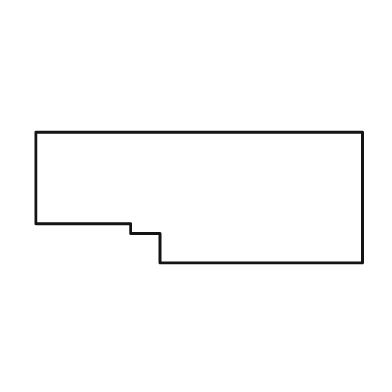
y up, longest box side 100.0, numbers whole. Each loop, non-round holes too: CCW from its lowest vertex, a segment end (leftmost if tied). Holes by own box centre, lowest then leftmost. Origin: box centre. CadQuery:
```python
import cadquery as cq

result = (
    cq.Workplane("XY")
    .moveTo(-12.0, -20.0)
    .lineTo(50.0, -20.0)
    .lineTo(50.0, 20.0)
    .lineTo(-50.0, 20.0)
    .lineTo(-50.0, -8.0)
    .lineTo(-21.0, -8.0)
    .lineTo(-21.0, -11.0)
    .lineTo(-12.0, -11.0)
    .close()
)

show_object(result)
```